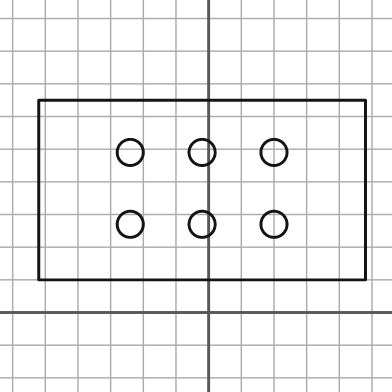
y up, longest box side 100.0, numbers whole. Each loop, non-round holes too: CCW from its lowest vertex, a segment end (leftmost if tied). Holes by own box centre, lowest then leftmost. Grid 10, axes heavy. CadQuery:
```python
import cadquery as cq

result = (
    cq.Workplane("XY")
    .moveTo(-52.0, 10.0)
    .lineTo(48.0, 10.0)
    .lineTo(48.0, 65.0)
    .lineTo(-52.0, 65.0)
    .close()
    .moveTo(-24.0, 27.0)
    .circle(4.0)
    .moveTo(-2.0, 27.0)
    .circle(4.0)
    .moveTo(20.0, 27.0)
    .circle(4.0)
    .moveTo(-24.0, 49.0)
    .circle(4.0)
    .moveTo(-2.0, 49.0)
    .circle(4.0)
    .moveTo(20.0, 49.0)
    .circle(4.0)
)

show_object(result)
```